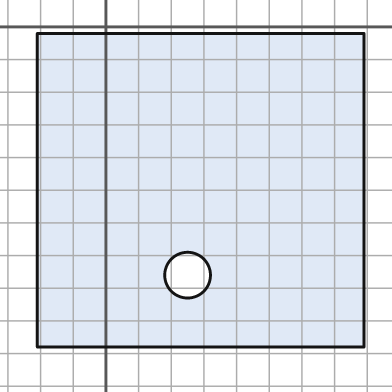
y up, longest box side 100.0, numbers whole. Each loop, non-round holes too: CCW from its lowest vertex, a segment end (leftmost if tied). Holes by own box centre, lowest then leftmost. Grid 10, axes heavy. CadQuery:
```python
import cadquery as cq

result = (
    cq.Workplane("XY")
    .moveTo(-21.0, -98.0)
    .lineTo(79.0, -98.0)
    .lineTo(79.0, -2.0)
    .lineTo(-21.0, -2.0)
    .close()
    .moveTo(25.0, -76.0)
    .circle(7.0)
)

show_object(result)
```